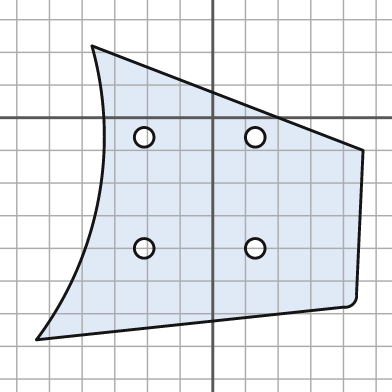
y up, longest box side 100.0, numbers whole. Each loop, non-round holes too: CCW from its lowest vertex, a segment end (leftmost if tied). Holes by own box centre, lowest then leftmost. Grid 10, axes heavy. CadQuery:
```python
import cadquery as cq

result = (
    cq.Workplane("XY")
    .moveTo(-54.0, -68.0)
    .lineTo(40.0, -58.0)
    .threePointArc((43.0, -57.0), (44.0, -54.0))
    .lineTo(46.0, -10.0)
    .lineTo(-37.0, 22.0)
    .threePointArc((-35.0, -25.0), (-54.0, -68.0))
    .close()
    .moveTo(-21.0, -40.0)
    .circle(3.0)
    .moveTo(13.0, -40.0)
    .circle(3.0)
    .moveTo(-21.0, -6.0)
    .circle(3.0)
    .moveTo(13.0, -6.0)
    .circle(3.0)
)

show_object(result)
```